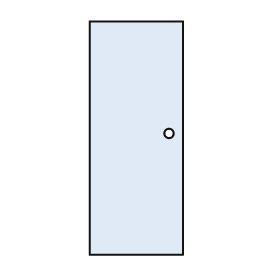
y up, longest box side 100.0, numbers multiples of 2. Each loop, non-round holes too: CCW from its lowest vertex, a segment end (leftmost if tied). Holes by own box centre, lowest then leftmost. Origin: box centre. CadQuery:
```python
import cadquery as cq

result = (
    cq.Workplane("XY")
    .moveTo(-20.0, -50.0)
    .lineTo(20.0, -50.0)
    .lineTo(20.0, 50.0)
    .lineTo(-20.0, 50.0)
    .close()
    .moveTo(14.0, 2.0)
    .circle(2.0)
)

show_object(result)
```